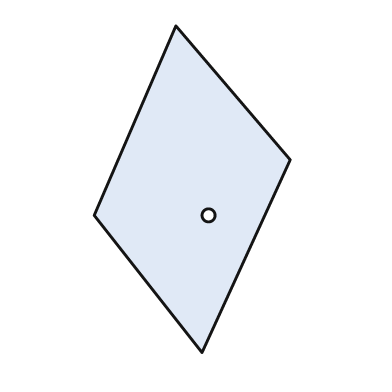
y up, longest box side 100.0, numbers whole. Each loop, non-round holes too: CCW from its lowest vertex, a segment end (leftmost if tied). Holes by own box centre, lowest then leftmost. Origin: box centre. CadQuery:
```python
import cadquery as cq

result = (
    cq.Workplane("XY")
    .moveTo(3.0, -50.0)
    .lineTo(30.0, 9.0)
    .lineTo(-5.0, 50.0)
    .lineTo(-30.0, -8.0)
    .close()
    .moveTo(5.0, -8.0)
    .circle(2.0)
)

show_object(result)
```